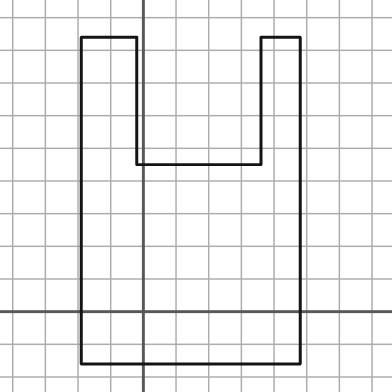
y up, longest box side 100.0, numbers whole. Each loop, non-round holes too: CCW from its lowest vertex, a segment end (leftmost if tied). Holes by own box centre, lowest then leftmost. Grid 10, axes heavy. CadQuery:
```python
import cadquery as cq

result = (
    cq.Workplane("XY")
    .moveTo(-19.0, -16.0)
    .lineTo(48.0, -16.0)
    .lineTo(48.0, 84.0)
    .lineTo(36.0, 84.0)
    .lineTo(36.0, 45.0)
    .lineTo(-2.0, 45.0)
    .lineTo(-2.0, 84.0)
    .lineTo(-19.0, 84.0)
    .close()
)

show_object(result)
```